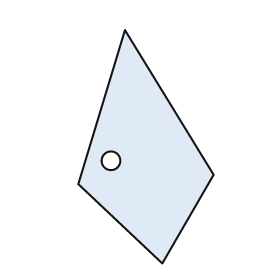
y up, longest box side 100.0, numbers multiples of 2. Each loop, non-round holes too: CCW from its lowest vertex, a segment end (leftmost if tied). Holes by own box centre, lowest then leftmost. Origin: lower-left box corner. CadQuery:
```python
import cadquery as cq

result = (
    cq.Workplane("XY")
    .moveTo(36.0, 0.0)
    .lineTo(58.0, 38.0)
    .lineTo(20.0, 100.0)
    .lineTo(0.0, 34.0)
    .close()
    .moveTo(14.0, 44.0)
    .circle(4.0)
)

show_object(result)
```